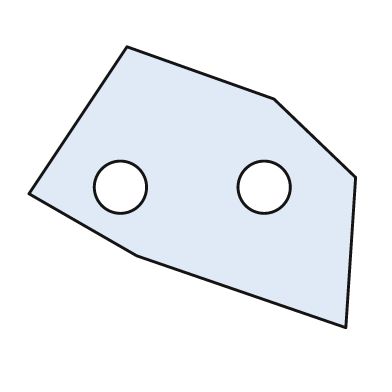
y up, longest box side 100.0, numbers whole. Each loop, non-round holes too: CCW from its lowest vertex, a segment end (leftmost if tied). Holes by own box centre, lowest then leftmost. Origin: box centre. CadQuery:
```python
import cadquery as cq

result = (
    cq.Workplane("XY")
    .moveTo(47.0, -43.0)
    .lineTo(50.0, 3.0)
    .lineTo(25.0, 27.0)
    .lineTo(-20.0, 43.0)
    .lineTo(-50.0, -2.0)
    .lineTo(-17.0, -21.0)
    .close()
    .moveTo(-22.0, 0.0)
    .circle(8.0)
    .moveTo(22.0, 0.0)
    .circle(8.0)
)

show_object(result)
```